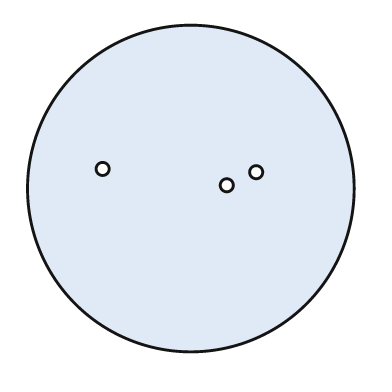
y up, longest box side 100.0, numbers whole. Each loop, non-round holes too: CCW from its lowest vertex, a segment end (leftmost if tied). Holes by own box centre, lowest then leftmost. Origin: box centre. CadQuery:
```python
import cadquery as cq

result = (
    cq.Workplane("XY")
    .moveTo(0.0, 0.0)
    .circle(50.0)
    .moveTo(11.0, 1.0)
    .circle(2.0)
    .moveTo(20.0, 5.0)
    .circle(2.0)
    .moveTo(-27.0, 6.0)
    .circle(2.0)
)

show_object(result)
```